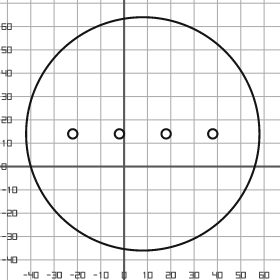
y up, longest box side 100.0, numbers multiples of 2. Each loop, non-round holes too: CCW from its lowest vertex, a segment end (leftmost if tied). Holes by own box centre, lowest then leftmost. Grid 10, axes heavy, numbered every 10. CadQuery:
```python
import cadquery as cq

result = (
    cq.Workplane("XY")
    .moveTo(8.0, 14.0)
    .circle(50.0)
    .moveTo(-22.0, 14.0)
    .circle(2.0)
    .moveTo(-2.0, 14.0)
    .circle(2.0)
    .moveTo(18.0, 14.0)
    .circle(2.0)
    .moveTo(38.0, 14.0)
    .circle(2.0)
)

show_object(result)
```